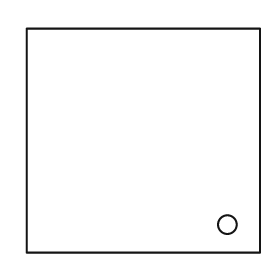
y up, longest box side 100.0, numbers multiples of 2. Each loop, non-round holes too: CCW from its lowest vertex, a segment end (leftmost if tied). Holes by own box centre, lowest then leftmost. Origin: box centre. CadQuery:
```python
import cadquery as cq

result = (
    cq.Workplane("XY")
    .moveTo(-50.0, -48.0)
    .lineTo(50.0, -48.0)
    .lineTo(50.0, 48.0)
    .lineTo(-50.0, 48.0)
    .close()
    .moveTo(36.0, -36.0)
    .circle(4.0)
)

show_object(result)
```